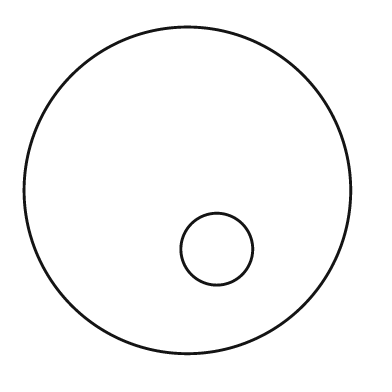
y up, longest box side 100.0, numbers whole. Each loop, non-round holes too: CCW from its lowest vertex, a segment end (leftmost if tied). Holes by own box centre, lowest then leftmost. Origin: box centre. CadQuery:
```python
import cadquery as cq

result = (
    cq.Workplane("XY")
    .moveTo(0.0, 0.0)
    .circle(50.0)
    .moveTo(9.0, -18.0)
    .circle(11.0)
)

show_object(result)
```